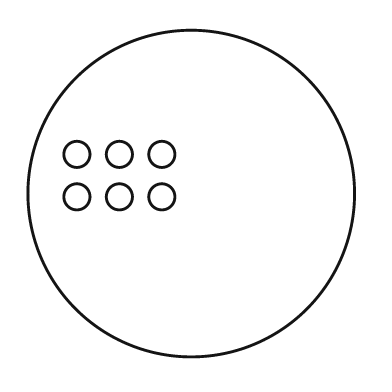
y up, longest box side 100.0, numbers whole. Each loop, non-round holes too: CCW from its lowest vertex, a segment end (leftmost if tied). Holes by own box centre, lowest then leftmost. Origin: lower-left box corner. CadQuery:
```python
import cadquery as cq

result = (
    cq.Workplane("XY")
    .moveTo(50.0, 50.0)
    .circle(50.0)
    .moveTo(15.0, 49.0)
    .circle(4.0)
    .moveTo(28.0, 49.0)
    .circle(4.0)
    .moveTo(41.0, 49.0)
    .circle(4.0)
    .moveTo(15.0, 62.0)
    .circle(4.0)
    .moveTo(28.0, 62.0)
    .circle(4.0)
    .moveTo(41.0, 62.0)
    .circle(4.0)
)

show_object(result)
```